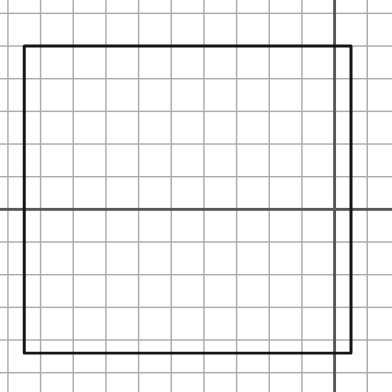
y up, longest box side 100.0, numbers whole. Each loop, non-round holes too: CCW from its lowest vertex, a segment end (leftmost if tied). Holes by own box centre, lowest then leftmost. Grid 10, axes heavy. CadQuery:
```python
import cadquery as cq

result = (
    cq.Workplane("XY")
    .moveTo(-95.0, -44.0)
    .lineTo(5.0, -44.0)
    .lineTo(5.0, 50.0)
    .lineTo(-95.0, 50.0)
    .close()
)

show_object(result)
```